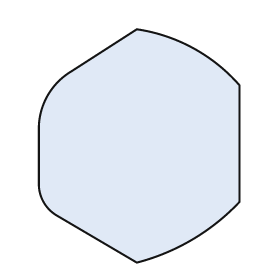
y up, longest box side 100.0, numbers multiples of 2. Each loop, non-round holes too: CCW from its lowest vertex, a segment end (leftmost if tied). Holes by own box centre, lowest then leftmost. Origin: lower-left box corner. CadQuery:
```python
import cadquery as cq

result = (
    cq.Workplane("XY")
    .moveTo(42.0, 0.0)
    .threePointArc((66.0, 10.0), (86.0, 26.0))
    .lineTo(86.0, 76.0)
    .threePointArc((66.0, 92.0), (42.0, 100.0))
    .lineTo(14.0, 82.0)
    .threePointArc((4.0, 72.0), (0.0, 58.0))
    .lineTo(0.0, 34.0)
    .threePointArc((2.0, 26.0), (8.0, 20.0))
    .close()
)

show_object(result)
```